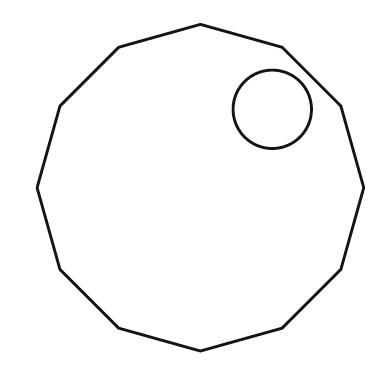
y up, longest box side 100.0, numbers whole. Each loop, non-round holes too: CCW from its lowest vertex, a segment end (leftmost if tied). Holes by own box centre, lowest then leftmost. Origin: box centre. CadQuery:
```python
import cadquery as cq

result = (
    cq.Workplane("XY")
    .moveTo(0.0, -50.0)
    .lineTo(25.0, -43.0)
    .lineTo(43.0, -25.0)
    .lineTo(50.0, 0.0)
    .lineTo(43.0, 25.0)
    .lineTo(25.0, 43.0)
    .lineTo(0.0, 50.0)
    .lineTo(-25.0, 43.0)
    .lineTo(-43.0, 25.0)
    .lineTo(-50.0, 0.0)
    .lineTo(-43.0, -25.0)
    .lineTo(-25.0, -43.0)
    .close()
    .moveTo(22.0, 24.0)
    .circle(12.0)
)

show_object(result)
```